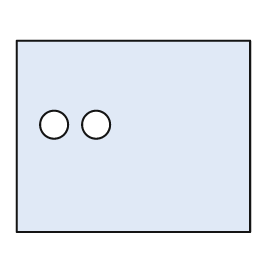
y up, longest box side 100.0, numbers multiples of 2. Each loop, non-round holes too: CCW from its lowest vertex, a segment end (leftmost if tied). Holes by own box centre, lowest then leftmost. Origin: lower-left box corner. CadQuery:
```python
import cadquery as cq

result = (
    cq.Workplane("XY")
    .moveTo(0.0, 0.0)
    .lineTo(100.0, 0.0)
    .lineTo(100.0, 82.0)
    .lineTo(0.0, 82.0)
    .close()
    .moveTo(16.0, 46.0)
    .circle(6.0)
    .moveTo(34.0, 46.0)
    .circle(6.0)
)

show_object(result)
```